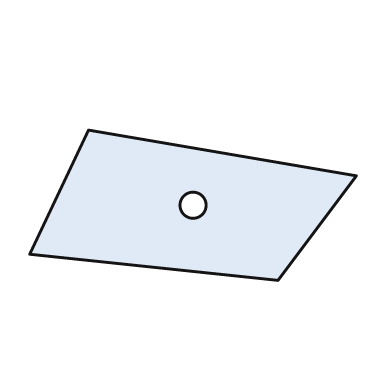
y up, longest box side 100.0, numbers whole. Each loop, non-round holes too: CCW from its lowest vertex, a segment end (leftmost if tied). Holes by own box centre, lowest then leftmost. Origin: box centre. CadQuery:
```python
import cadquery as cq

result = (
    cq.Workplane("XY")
    .moveTo(26.0, -23.0)
    .lineTo(50.0, 9.0)
    .lineTo(-32.0, 23.0)
    .lineTo(-50.0, -15.0)
    .close()
    .moveTo(0.0, 0.0)
    .circle(4.0)
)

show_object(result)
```